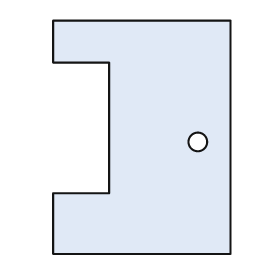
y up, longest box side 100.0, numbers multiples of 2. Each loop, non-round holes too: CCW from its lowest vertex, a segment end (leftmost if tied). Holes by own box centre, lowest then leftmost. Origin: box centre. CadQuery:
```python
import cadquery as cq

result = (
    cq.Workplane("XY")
    .moveTo(-38.0, -50.0)
    .lineTo(38.0, -50.0)
    .lineTo(38.0, 50.0)
    .lineTo(-38.0, 50.0)
    .lineTo(-38.0, 32.0)
    .lineTo(-14.0, 32.0)
    .lineTo(-14.0, -24.0)
    .lineTo(-38.0, -24.0)
    .close()
    .moveTo(24.0, -2.0)
    .circle(4.0)
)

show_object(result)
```